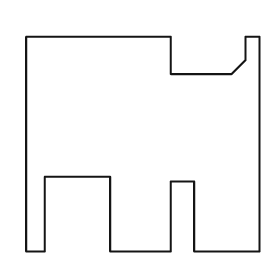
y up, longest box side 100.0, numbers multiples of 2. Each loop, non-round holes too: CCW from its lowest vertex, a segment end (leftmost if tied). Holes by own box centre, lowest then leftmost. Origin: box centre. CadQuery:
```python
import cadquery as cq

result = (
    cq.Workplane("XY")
    .moveTo(-50.0, -46.0)
    .lineTo(-42.0, -46.0)
    .lineTo(-42.0, -14.0)
    .lineTo(-14.0, -14.0)
    .lineTo(-14.0, -46.0)
    .lineTo(12.0, -46.0)
    .lineTo(12.0, -16.0)
    .lineTo(22.0, -16.0)
    .lineTo(22.0, -46.0)
    .lineTo(50.0, -46.0)
    .lineTo(50.0, 46.0)
    .lineTo(44.0, 46.0)
    .lineTo(44.0, 36.0)
    .lineTo(38.0, 30.0)
    .lineTo(12.0, 30.0)
    .lineTo(12.0, 46.0)
    .lineTo(-50.0, 46.0)
    .close()
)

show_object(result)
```